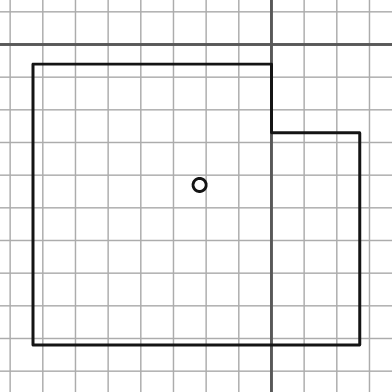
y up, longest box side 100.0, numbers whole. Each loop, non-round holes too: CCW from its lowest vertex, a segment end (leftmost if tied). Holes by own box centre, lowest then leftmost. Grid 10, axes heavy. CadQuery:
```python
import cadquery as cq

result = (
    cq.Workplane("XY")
    .moveTo(-73.0, -92.0)
    .lineTo(27.0, -92.0)
    .lineTo(27.0, -27.0)
    .lineTo(0.0, -27.0)
    .lineTo(0.0, -6.0)
    .lineTo(-73.0, -6.0)
    .close()
    .moveTo(-22.0, -43.0)
    .circle(2.0)
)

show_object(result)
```